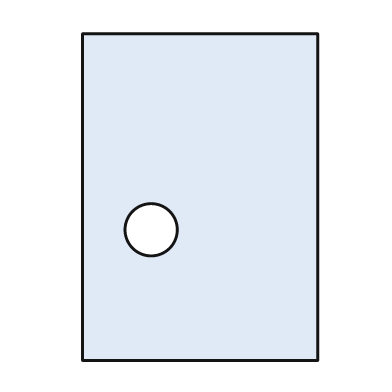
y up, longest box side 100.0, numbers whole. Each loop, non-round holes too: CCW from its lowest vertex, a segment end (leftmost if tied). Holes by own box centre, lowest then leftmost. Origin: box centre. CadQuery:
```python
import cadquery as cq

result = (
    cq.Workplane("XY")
    .moveTo(-36.0, -50.0)
    .lineTo(36.0, -50.0)
    .lineTo(36.0, 50.0)
    .lineTo(-36.0, 50.0)
    .close()
    .moveTo(-15.0, -10.0)
    .circle(8.0)
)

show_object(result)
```